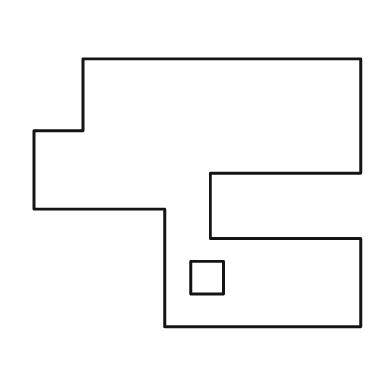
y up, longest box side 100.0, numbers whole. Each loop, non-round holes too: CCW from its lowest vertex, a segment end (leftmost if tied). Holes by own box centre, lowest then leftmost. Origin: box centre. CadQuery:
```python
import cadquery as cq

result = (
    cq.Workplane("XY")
    .moveTo(-10.0, -41.0)
    .lineTo(50.0, -41.0)
    .lineTo(50.0, -14.0)
    .lineTo(4.0, -14.0)
    .lineTo(4.0, 6.0)
    .lineTo(50.0, 6.0)
    .lineTo(50.0, 41.0)
    .lineTo(-35.0, 41.0)
    .lineTo(-35.0, 19.0)
    .lineTo(-50.0, 19.0)
    .lineTo(-50.0, -5.0)
    .lineTo(-10.0, -5.0)
    .close()
    .moveTo(-2.0, -31.0)
    .lineTo(8.0, -31.0)
    .lineTo(8.0, -21.0)
    .lineTo(-2.0, -21.0)
    .close()
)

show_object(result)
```